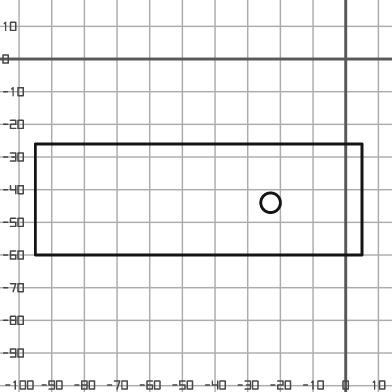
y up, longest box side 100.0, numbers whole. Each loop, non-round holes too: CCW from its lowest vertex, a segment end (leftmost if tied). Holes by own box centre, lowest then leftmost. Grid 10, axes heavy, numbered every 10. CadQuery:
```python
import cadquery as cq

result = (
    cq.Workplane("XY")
    .moveTo(-95.0, -60.0)
    .lineTo(5.0, -60.0)
    .lineTo(5.0, -26.0)
    .lineTo(-95.0, -26.0)
    .close()
    .moveTo(-23.0, -44.0)
    .circle(3.0)
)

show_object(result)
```